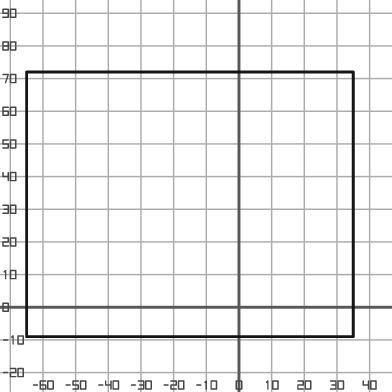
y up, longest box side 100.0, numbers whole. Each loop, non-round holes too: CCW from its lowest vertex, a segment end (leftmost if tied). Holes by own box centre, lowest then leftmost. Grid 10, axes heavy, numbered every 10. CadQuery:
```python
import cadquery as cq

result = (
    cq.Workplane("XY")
    .moveTo(-65.0, -9.0)
    .lineTo(35.0, -9.0)
    .lineTo(35.0, 72.0)
    .lineTo(-65.0, 72.0)
    .close()
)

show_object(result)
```